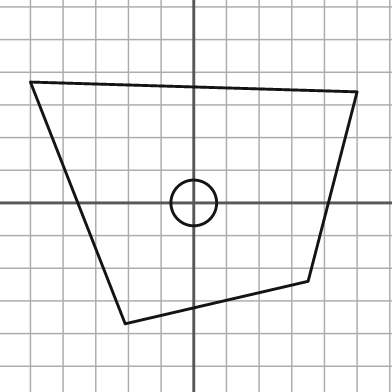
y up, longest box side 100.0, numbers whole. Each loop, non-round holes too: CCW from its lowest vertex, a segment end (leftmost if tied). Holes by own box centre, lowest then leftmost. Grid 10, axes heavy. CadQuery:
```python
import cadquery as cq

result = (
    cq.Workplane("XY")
    .moveTo(-21.0, -37.0)
    .lineTo(35.0, -24.0)
    .lineTo(50.0, 34.0)
    .lineTo(-50.0, 37.0)
    .close()
    .moveTo(0.0, 0.0)
    .circle(7.0)
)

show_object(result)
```